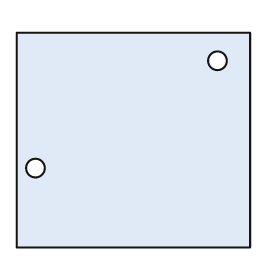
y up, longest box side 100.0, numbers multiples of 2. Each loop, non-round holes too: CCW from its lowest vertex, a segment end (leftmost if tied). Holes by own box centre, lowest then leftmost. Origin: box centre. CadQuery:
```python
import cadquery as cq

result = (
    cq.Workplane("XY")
    .moveTo(-50.0, -46.0)
    .lineTo(50.0, -46.0)
    .lineTo(50.0, 46.0)
    .lineTo(-50.0, 46.0)
    .close()
    .moveTo(-42.0, -12.0)
    .circle(4.0)
    .moveTo(36.0, 34.0)
    .circle(4.0)
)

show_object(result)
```